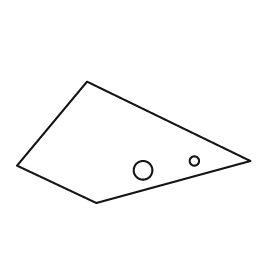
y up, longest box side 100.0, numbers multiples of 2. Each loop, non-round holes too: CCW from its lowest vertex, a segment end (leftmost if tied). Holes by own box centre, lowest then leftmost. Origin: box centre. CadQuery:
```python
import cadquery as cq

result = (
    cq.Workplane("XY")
    .moveTo(-16.0, -26.0)
    .lineTo(50.0, -8.0)
    .lineTo(-20.0, 26.0)
    .lineTo(-50.0, -10.0)
    .close()
    .moveTo(4.0, -12.0)
    .circle(4.0)
    .moveTo(26.0, -8.0)
    .circle(2.0)
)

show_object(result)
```